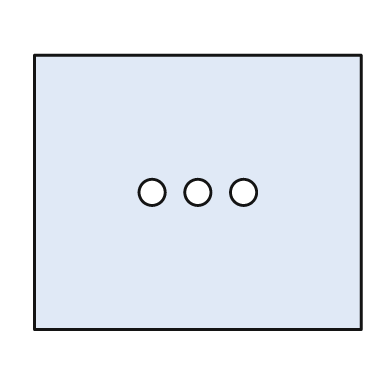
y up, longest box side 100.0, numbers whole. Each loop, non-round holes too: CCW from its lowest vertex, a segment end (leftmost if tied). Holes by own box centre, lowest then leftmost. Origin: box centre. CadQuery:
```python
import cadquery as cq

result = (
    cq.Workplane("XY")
    .moveTo(-50.0, -42.0)
    .lineTo(50.0, -42.0)
    .lineTo(50.0, 42.0)
    .lineTo(-50.0, 42.0)
    .close()
    .moveTo(-14.0, 0.0)
    .circle(4.0)
    .moveTo(0.0, 0.0)
    .circle(4.0)
    .moveTo(14.0, 0.0)
    .circle(4.0)
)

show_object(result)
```